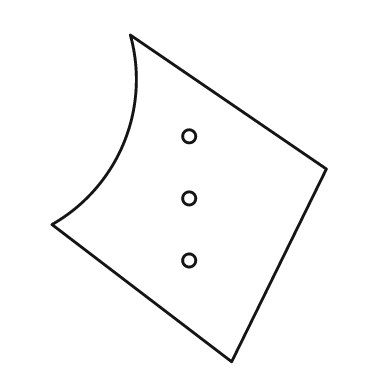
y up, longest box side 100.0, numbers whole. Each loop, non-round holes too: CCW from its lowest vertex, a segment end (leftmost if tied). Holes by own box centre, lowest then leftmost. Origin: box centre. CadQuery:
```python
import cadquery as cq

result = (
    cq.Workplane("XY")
    .moveTo(13.0, -50.0)
    .lineTo(42.0, 9.0)
    .lineTo(-18.0, 50.0)
    .threePointArc((-20.0, 17.0), (-42.0, -8.0))
    .close()
    .moveTo(0.0, -19.0)
    .circle(2.0)
    .moveTo(0.0, 0.0)
    .circle(2.0)
    .moveTo(0.0, 19.0)
    .circle(2.0)
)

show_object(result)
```